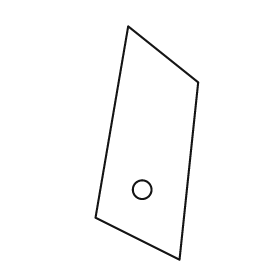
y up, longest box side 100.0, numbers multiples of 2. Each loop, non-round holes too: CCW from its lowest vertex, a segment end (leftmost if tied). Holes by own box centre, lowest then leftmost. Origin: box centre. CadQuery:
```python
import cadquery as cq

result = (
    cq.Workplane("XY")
    .moveTo(14.0, -50.0)
    .lineTo(22.0, 26.0)
    .lineTo(-8.0, 50.0)
    .lineTo(-22.0, -32.0)
    .close()
    .moveTo(-2.0, -20.0)
    .circle(4.0)
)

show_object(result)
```